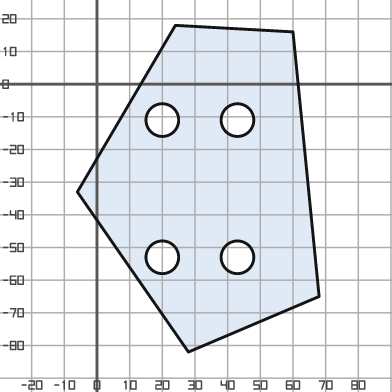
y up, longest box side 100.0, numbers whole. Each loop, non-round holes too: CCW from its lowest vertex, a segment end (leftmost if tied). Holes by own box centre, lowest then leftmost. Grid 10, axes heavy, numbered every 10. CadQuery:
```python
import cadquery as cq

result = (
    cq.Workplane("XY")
    .moveTo(28.0, -82.0)
    .lineTo(68.0, -65.0)
    .lineTo(60.0, 16.0)
    .lineTo(24.0, 18.0)
    .lineTo(-6.0, -33.0)
    .close()
    .moveTo(20.0, -53.0)
    .circle(5.0)
    .moveTo(43.0, -53.0)
    .circle(5.0)
    .moveTo(20.0, -11.0)
    .circle(5.0)
    .moveTo(43.0, -11.0)
    .circle(5.0)
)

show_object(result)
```